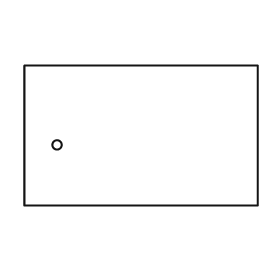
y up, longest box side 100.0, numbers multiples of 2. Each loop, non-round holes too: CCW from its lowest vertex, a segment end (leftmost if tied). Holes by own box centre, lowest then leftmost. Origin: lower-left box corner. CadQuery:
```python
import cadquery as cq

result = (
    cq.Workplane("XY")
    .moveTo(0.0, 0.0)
    .lineTo(100.0, 0.0)
    .lineTo(100.0, 60.0)
    .lineTo(0.0, 60.0)
    .close()
    .moveTo(14.0, 26.0)
    .circle(2.0)
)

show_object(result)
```